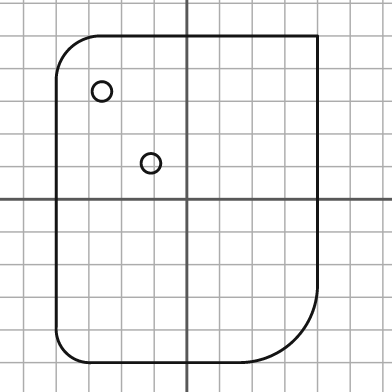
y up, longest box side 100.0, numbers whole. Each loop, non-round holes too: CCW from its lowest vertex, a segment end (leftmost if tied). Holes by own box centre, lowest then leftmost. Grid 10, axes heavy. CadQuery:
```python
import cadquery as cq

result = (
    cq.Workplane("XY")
    .moveTo(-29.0, -50.0)
    .lineTo(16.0, -50.0)
    .threePointArc((33.0, -43.0), (40.0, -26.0))
    .lineTo(40.0, 50.0)
    .lineTo(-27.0, 50.0)
    .threePointArc((-36.0, 46.0), (-40.0, 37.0))
    .lineTo(-40.0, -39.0)
    .threePointArc((-37.0, -47.0), (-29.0, -50.0))
    .close()
    .moveTo(-11.0, 11.0)
    .circle(3.0)
    .moveTo(-26.0, 33.0)
    .circle(3.0)
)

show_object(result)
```